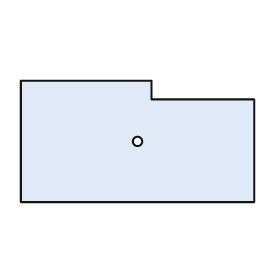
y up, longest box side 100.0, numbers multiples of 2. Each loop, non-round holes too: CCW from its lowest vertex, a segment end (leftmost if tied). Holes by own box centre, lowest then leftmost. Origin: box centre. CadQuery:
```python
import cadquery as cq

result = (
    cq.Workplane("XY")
    .moveTo(-50.0, -26.0)
    .lineTo(50.0, -26.0)
    .lineTo(50.0, 18.0)
    .lineTo(6.0, 18.0)
    .lineTo(6.0, 26.0)
    .lineTo(-50.0, 26.0)
    .close()
    .moveTo(0.0, 0.0)
    .circle(2.0)
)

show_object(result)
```